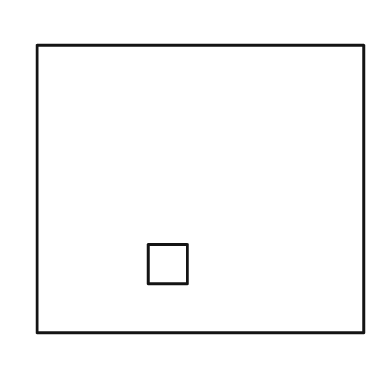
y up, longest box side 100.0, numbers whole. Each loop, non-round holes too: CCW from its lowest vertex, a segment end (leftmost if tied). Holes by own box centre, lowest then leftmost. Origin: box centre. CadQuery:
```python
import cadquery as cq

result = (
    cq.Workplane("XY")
    .moveTo(-50.0, -44.0)
    .lineTo(50.0, -44.0)
    .lineTo(50.0, 44.0)
    .lineTo(-50.0, 44.0)
    .close()
    .moveTo(-16.0, -29.0)
    .lineTo(-4.0, -29.0)
    .lineTo(-4.0, -17.0)
    .lineTo(-16.0, -17.0)
    .close()
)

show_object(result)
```